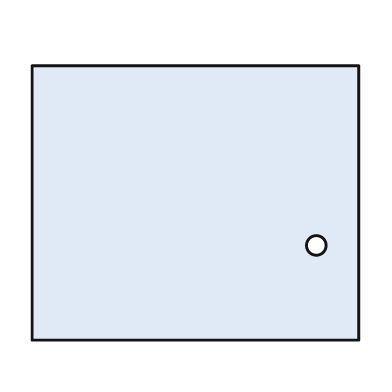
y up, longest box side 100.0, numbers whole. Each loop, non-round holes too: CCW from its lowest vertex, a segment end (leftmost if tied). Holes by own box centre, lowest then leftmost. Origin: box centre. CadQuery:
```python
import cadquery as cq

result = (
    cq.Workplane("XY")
    .moveTo(-50.0, -42.0)
    .lineTo(50.0, -42.0)
    .lineTo(50.0, 42.0)
    .lineTo(-50.0, 42.0)
    .close()
    .moveTo(37.0, -13.0)
    .circle(3.0)
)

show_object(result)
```